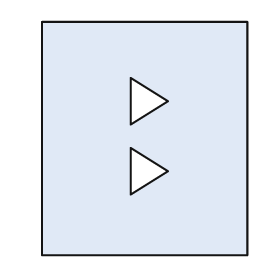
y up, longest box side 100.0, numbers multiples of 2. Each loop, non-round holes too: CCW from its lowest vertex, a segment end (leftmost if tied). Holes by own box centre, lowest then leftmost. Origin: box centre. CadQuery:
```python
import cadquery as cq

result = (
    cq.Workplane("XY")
    .moveTo(-44.0, -50.0)
    .lineTo(44.0, -50.0)
    .lineTo(44.0, 50.0)
    .lineTo(-44.0, 50.0)
    .close()
    .moveTo(-6.0, -24.0)
    .lineTo(10.0, -14.0)
    .lineTo(-6.0, -4.0)
    .close()
    .moveTo(-6.0, 6.0)
    .lineTo(10.0, 16.0)
    .lineTo(-6.0, 26.0)
    .close()
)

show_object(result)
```